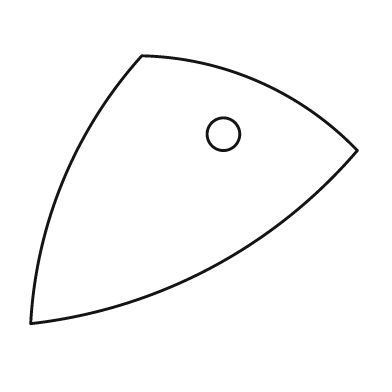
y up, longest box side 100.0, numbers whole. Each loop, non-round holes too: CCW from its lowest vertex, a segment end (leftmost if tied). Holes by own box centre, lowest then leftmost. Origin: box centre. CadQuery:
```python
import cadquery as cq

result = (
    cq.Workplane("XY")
    .moveTo(-50.0, -41.0)
    .threePointArc((5.0, -24.0), (50.0, 12.0))
    .threePointArc((20.0, 33.0), (-16.0, 41.0))
    .threePointArc((-40.0, 3.0), (-50.0, -41.0))
    .close()
    .moveTo(9.0, 17.0)
    .circle(5.0)
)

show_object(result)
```